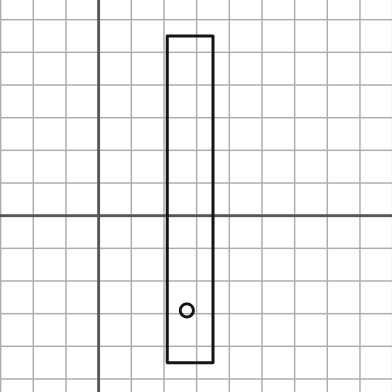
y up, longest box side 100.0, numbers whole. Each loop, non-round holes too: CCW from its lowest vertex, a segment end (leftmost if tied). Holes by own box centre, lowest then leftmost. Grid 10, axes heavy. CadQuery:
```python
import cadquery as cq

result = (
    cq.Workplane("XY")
    .moveTo(21.0, -45.0)
    .lineTo(35.0, -45.0)
    .lineTo(35.0, 55.0)
    .lineTo(21.0, 55.0)
    .close()
    .moveTo(27.0, -29.0)
    .circle(2.0)
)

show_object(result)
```